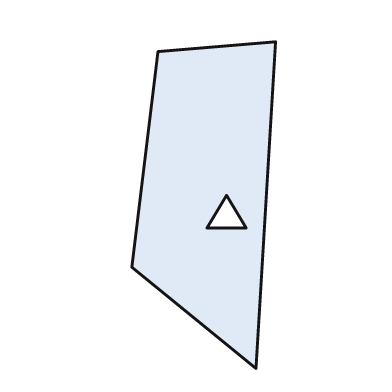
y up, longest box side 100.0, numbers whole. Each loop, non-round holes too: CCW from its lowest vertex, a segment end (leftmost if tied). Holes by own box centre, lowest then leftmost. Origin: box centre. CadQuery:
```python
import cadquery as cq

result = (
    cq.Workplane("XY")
    .moveTo(16.0, -50.0)
    .lineTo(22.0, 50.0)
    .lineTo(-14.0, 47.0)
    .lineTo(-22.0, -19.0)
    .close()
    .moveTo(1.0, -7.0)
    .lineTo(13.0, -7.0)
    .lineTo(7.0, 3.0)
    .close()
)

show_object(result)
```